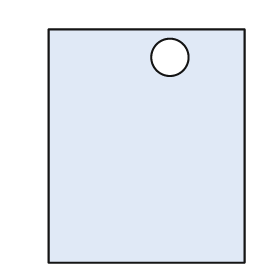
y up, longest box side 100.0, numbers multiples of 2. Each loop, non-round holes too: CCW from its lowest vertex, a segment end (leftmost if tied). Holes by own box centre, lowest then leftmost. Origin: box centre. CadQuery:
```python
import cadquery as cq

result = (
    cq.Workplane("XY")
    .moveTo(-42.0, -50.0)
    .lineTo(42.0, -50.0)
    .lineTo(42.0, 50.0)
    .lineTo(-42.0, 50.0)
    .close()
    .moveTo(10.0, 38.0)
    .circle(8.0)
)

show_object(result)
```